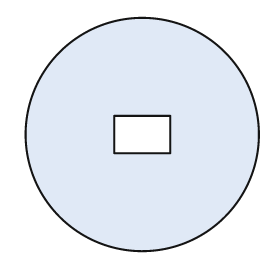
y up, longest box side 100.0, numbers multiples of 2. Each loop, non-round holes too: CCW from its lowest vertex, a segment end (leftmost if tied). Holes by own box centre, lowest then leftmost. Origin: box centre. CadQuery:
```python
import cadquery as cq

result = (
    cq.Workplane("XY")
    .moveTo(0.0, 0.0)
    .circle(50.0)
    .moveTo(-12.0, -8.0)
    .lineTo(12.0, -8.0)
    .lineTo(12.0, 8.0)
    .lineTo(-12.0, 8.0)
    .close()
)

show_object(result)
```